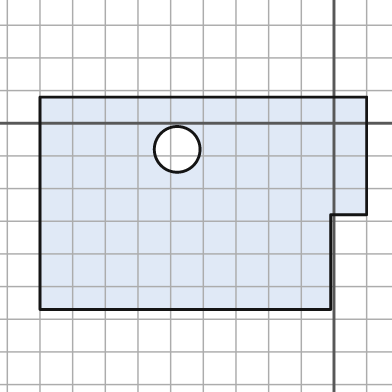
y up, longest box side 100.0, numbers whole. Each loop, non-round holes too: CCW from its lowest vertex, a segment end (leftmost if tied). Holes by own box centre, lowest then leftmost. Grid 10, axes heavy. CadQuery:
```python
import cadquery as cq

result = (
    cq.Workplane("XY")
    .moveTo(-90.0, -57.0)
    .lineTo(-1.0, -57.0)
    .lineTo(-1.0, -28.0)
    .lineTo(10.0, -28.0)
    .lineTo(10.0, 8.0)
    .lineTo(-90.0, 8.0)
    .close()
    .moveTo(-48.0, -8.0)
    .circle(7.0)
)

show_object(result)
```